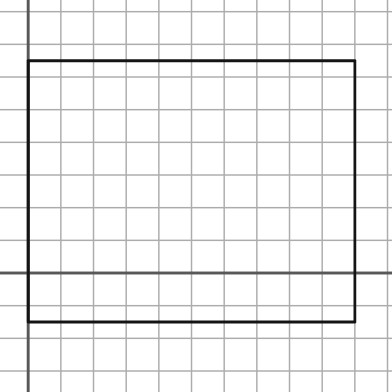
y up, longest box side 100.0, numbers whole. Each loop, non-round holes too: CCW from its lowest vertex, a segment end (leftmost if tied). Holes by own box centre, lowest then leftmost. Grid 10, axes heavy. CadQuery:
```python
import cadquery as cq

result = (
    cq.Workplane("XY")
    .moveTo(0.0, -15.0)
    .lineTo(100.0, -15.0)
    .lineTo(100.0, 65.0)
    .lineTo(0.0, 65.0)
    .close()
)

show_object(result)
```